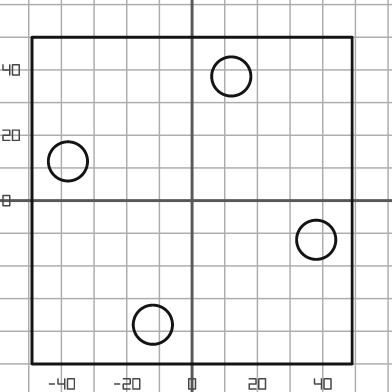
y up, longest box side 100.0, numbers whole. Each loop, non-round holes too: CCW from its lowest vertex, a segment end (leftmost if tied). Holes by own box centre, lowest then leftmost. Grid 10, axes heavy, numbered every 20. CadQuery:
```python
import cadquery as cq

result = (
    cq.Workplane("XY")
    .moveTo(-49.0, -50.0)
    .lineTo(49.0, -50.0)
    .lineTo(49.0, 50.0)
    .lineTo(-49.0, 50.0)
    .close()
    .moveTo(-12.0, -38.0)
    .circle(6.0)
    .moveTo(38.0, -12.0)
    .circle(6.0)
    .moveTo(-38.0, 12.0)
    .circle(6.0)
    .moveTo(12.0, 38.0)
    .circle(6.0)
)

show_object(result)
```